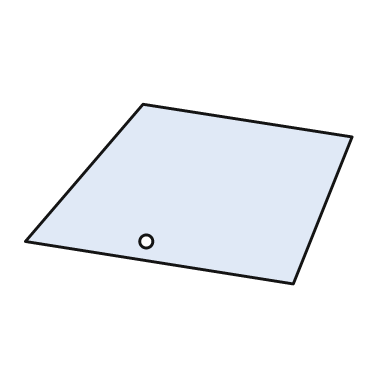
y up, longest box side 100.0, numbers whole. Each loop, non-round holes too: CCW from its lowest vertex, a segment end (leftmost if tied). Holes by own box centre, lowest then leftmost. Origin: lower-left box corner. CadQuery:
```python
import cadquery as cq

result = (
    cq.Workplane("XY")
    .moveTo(82.0, 0.0)
    .lineTo(100.0, 45.0)
    .lineTo(36.0, 55.0)
    .lineTo(0.0, 13.0)
    .close()
    .moveTo(37.0, 13.0)
    .circle(2.0)
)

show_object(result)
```